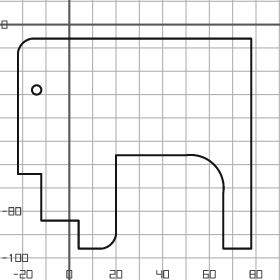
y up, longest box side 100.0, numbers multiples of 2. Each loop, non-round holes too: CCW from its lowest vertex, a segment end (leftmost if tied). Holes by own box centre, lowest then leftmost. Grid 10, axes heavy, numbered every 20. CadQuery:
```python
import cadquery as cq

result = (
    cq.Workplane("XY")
    .moveTo(4.0, -96.0)
    .lineTo(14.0, -96.0)
    .threePointArc((18.0, -94.0), (20.0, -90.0))
    .lineTo(20.0, -56.0)
    .lineTo(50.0, -56.0)
    .threePointArc((62.0, -60.0), (66.0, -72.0))
    .lineTo(66.0, -96.0)
    .lineTo(78.0, -96.0)
    .lineTo(78.0, -6.0)
    .lineTo(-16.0, -6.0)
    .threePointArc((-20.0, -8.0), (-22.0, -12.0))
    .lineTo(-22.0, -64.0)
    .lineTo(-12.0, -64.0)
    .lineTo(-12.0, -84.0)
    .lineTo(4.0, -84.0)
    .close()
    .moveTo(-14.0, -28.0)
    .circle(2.0)
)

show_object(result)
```